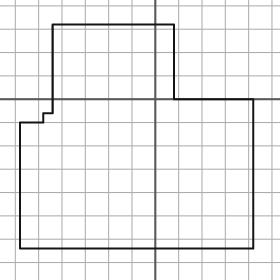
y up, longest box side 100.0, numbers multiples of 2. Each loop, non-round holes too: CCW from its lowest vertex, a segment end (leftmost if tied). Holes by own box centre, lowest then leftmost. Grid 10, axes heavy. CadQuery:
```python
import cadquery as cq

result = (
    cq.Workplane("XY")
    .moveTo(-58.0, -64.0)
    .lineTo(42.0, -64.0)
    .lineTo(42.0, 0.0)
    .lineTo(8.0, 0.0)
    .lineTo(8.0, 32.0)
    .lineTo(-44.0, 32.0)
    .lineTo(-44.0, -6.0)
    .lineTo(-48.0, -6.0)
    .lineTo(-48.0, -10.0)
    .lineTo(-58.0, -10.0)
    .close()
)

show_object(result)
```